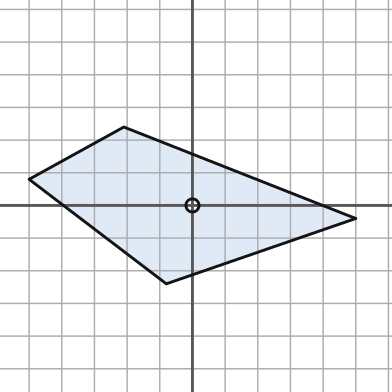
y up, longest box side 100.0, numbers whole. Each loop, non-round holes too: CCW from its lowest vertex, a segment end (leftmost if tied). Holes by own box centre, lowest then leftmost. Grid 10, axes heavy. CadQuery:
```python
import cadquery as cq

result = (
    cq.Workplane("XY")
    .moveTo(-8.0, -24.0)
    .lineTo(50.0, -4.0)
    .lineTo(-21.0, 24.0)
    .lineTo(-50.0, 8.0)
    .close()
    .moveTo(0.0, 0.0)
    .circle(2.0)
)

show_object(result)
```